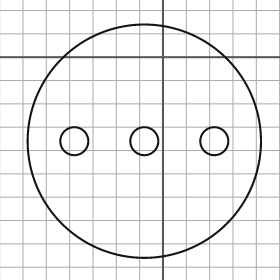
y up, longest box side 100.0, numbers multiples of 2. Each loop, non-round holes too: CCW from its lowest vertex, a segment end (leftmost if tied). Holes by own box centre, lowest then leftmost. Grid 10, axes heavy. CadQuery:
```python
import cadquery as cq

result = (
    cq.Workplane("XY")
    .moveTo(-8.0, -36.0)
    .circle(50.0)
    .moveTo(-38.0, -36.0)
    .circle(6.0)
    .moveTo(-8.0, -36.0)
    .circle(6.0)
    .moveTo(22.0, -36.0)
    .circle(6.0)
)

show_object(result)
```